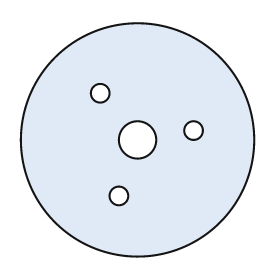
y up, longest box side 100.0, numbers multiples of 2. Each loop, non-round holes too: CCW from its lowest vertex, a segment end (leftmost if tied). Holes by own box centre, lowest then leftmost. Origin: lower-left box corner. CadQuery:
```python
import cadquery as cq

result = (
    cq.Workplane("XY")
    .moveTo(50.0, 50.0)
    .circle(50.0)
    .moveTo(42.0, 26.0)
    .circle(4.0)
    .moveTo(50.0, 50.0)
    .circle(8.0)
    .moveTo(74.0, 54.0)
    .circle(4.0)
    .moveTo(34.0, 70.0)
    .circle(4.0)
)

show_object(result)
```